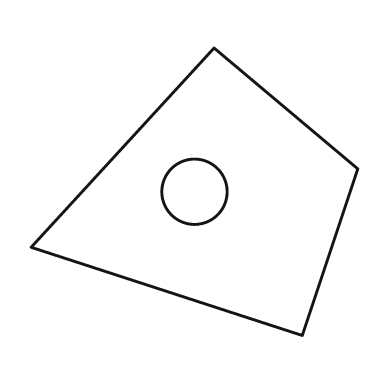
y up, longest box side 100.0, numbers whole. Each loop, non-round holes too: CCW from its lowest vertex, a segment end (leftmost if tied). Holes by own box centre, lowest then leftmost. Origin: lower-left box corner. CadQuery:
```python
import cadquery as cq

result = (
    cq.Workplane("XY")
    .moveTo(83.0, 0.0)
    .lineTo(100.0, 51.0)
    .lineTo(56.0, 88.0)
    .lineTo(0.0, 27.0)
    .close()
    .moveTo(50.0, 44.0)
    .circle(10.0)
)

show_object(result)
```